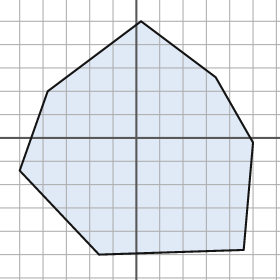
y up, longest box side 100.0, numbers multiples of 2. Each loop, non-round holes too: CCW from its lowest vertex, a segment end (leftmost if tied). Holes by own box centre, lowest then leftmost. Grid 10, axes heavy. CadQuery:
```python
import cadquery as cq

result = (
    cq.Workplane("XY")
    .moveTo(-16.0, -50.0)
    .lineTo(46.0, -48.0)
    .lineTo(50.0, -2.0)
    .lineTo(34.0, 26.0)
    .lineTo(2.0, 50.0)
    .lineTo(-38.0, 20.0)
    .lineTo(-50.0, -14.0)
    .close()
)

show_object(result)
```